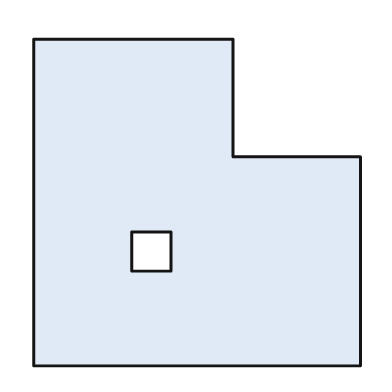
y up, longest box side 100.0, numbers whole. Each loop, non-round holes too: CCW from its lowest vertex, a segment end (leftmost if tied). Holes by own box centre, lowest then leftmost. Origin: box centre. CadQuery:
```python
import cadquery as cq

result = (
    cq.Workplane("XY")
    .moveTo(-50.0, -50.0)
    .lineTo(50.0, -50.0)
    .lineTo(50.0, 14.0)
    .lineTo(11.0, 14.0)
    .lineTo(11.0, 50.0)
    .lineTo(-50.0, 50.0)
    .close()
    .moveTo(-20.0, -21.0)
    .lineTo(-8.0, -21.0)
    .lineTo(-8.0, -9.0)
    .lineTo(-20.0, -9.0)
    .close()
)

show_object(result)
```